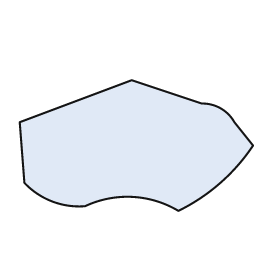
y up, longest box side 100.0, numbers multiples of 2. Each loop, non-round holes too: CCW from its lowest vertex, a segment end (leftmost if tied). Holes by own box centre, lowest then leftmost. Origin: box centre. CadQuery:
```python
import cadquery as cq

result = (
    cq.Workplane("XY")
    .moveTo(18.0, -28.0)
    .threePointArc((36.0, -16.0), (50.0, 0.0))
    .lineTo(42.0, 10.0)
    .threePointArc((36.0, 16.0), (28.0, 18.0))
    .lineTo(-2.0, 28.0)
    .lineTo(-50.0, 10.0)
    .lineTo(-48.0, -16.0)
    .threePointArc((-36.0, -24.0), (-22.0, -26.0))
    .threePointArc((-2.0, -22.0), (18.0, -28.0))
    .close()
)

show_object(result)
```